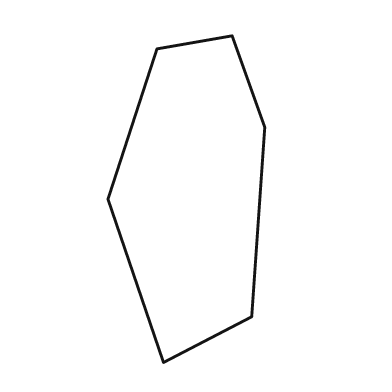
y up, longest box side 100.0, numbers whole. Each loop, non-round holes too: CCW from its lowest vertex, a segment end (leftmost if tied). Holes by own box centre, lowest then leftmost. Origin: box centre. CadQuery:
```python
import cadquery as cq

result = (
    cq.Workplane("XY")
    .moveTo(-7.0, -50.0)
    .lineTo(20.0, -36.0)
    .lineTo(24.0, 22.0)
    .lineTo(14.0, 50.0)
    .lineTo(-9.0, 46.0)
    .lineTo(-24.0, 0.0)
    .close()
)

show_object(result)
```